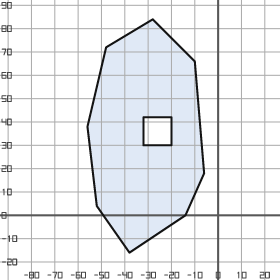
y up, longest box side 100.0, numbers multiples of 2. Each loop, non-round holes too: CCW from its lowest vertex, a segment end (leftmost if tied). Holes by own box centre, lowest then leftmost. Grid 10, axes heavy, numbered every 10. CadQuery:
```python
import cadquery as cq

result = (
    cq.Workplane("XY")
    .moveTo(-38.0, -16.0)
    .lineTo(-14.0, 0.0)
    .lineTo(-6.0, 18.0)
    .lineTo(-10.0, 66.0)
    .lineTo(-28.0, 84.0)
    .lineTo(-48.0, 72.0)
    .lineTo(-56.0, 38.0)
    .lineTo(-52.0, 4.0)
    .close()
    .moveTo(-32.0, 30.0)
    .lineTo(-20.0, 30.0)
    .lineTo(-20.0, 42.0)
    .lineTo(-32.0, 42.0)
    .close()
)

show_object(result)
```